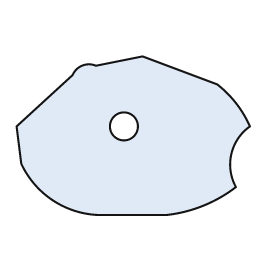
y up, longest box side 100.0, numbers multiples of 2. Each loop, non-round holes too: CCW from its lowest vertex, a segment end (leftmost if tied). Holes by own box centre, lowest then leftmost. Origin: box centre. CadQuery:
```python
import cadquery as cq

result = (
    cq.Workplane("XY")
    .moveTo(-14.0, -34.0)
    .lineTo(14.0, -34.0)
    .threePointArc((30.0, -30.0), (44.0, -22.0))
    .threePointArc((42.0, -8.0), (50.0, 4.0))
    .threePointArc((44.0, 14.0), (36.0, 22.0))
    .lineTo(4.0, 34.0)
    .lineTo(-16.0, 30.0)
    .threePointArc((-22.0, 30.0), (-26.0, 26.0))
    .lineTo(-50.0, 4.0)
    .lineTo(-48.0, -12.0)
    .threePointArc((-34.0, -28.0), (-14.0, -34.0))
    .close()
    .moveTo(-4.0, 4.0)
    .circle(6.0)
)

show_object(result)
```